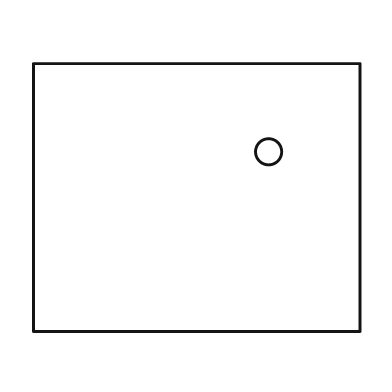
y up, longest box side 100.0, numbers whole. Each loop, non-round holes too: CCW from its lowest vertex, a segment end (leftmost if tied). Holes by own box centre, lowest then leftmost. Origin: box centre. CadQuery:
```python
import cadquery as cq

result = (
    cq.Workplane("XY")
    .moveTo(-50.0, -41.0)
    .lineTo(50.0, -41.0)
    .lineTo(50.0, 41.0)
    .lineTo(-50.0, 41.0)
    .close()
    .moveTo(22.0, 14.0)
    .circle(4.0)
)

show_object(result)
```